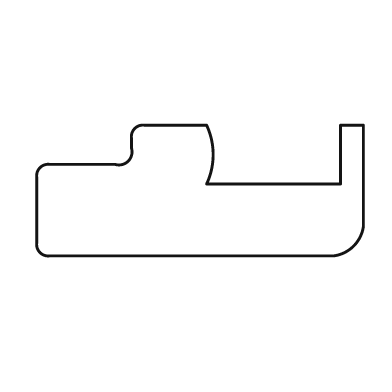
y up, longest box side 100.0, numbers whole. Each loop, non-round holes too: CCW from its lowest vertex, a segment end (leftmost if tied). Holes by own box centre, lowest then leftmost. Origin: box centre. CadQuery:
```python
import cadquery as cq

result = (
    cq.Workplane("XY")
    .moveTo(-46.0, -20.0)
    .lineTo(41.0, -20.0)
    .threePointArc((47.0, -17.0), (50.0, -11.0))
    .lineTo(50.0, 20.0)
    .lineTo(43.0, 20.0)
    .lineTo(43.0, 2.0)
    .lineTo(2.0, 2.0)
    .threePointArc((4.0, 11.0), (2.0, 20.0))
    .lineTo(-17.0, 20.0)
    .threePointArc((-20.0, 19.0), (-21.0, 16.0))
    .lineTo(-21.0, 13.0)
    .threePointArc((-22.0, 9.0), (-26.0, 8.0))
    .lineTo(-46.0, 8.0)
    .threePointArc((-49.0, 7.0), (-50.0, 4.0))
    .lineTo(-50.0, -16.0)
    .threePointArc((-49.0, -19.0), (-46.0, -20.0))
    .close()
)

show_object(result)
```